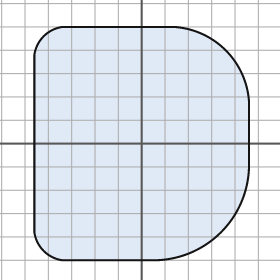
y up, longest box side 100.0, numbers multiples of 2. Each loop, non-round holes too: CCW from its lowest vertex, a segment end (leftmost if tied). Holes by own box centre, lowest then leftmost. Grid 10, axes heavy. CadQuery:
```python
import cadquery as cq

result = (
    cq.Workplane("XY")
    .moveTo(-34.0, -50.0)
    .lineTo(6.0, -50.0)
    .threePointArc((34.0, -38.0), (46.0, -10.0))
    .lineTo(46.0, 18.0)
    .threePointArc((36.0, 40.0), (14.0, 50.0))
    .lineTo(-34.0, 50.0)
    .threePointArc((-42.0, 46.0), (-46.0, 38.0))
    .lineTo(-46.0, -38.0)
    .threePointArc((-42.0, -46.0), (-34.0, -50.0))
    .close()
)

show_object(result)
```